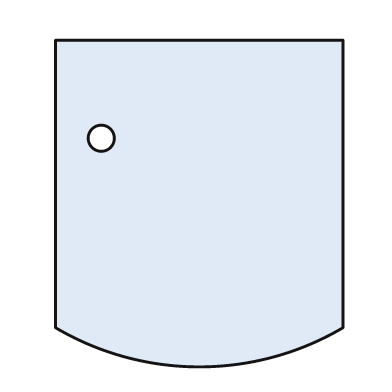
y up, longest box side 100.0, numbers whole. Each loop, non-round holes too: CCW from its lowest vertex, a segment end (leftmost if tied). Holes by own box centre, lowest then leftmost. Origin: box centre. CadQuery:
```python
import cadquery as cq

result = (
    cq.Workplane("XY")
    .moveTo(-44.0, -38.0)
    .threePointArc((0.0, -50.0), (44.0, -38.0))
    .lineTo(44.0, 50.0)
    .lineTo(-44.0, 50.0)
    .close()
    .moveTo(-30.0, 20.0)
    .circle(4.0)
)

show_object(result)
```